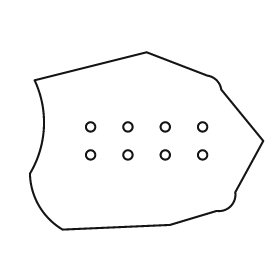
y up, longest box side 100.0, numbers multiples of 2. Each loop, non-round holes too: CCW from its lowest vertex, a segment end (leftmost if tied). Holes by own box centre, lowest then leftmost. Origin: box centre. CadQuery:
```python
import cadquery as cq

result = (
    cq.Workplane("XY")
    .moveTo(-36.0, -38.0)
    .lineTo(10.0, -36.0)
    .lineTo(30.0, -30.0)
    .threePointArc((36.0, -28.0), (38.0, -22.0))
    .lineTo(50.0, 0.0)
    .lineTo(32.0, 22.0)
    .threePointArc((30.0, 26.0), (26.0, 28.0))
    .lineTo(0.0, 38.0)
    .lineTo(-48.0, 26.0)
    .threePointArc((-44.0, 6.0), (-50.0, -14.0))
    .threePointArc((-46.0, -28.0), (-36.0, -38.0))
    .close()
    .moveTo(-24.0, -6.0)
    .circle(2.0)
    .moveTo(-8.0, -6.0)
    .circle(2.0)
    .moveTo(8.0, -6.0)
    .circle(2.0)
    .moveTo(24.0, -6.0)
    .circle(2.0)
    .moveTo(-24.0, 6.0)
    .circle(2.0)
    .moveTo(-8.0, 6.0)
    .circle(2.0)
    .moveTo(8.0, 6.0)
    .circle(2.0)
    .moveTo(24.0, 6.0)
    .circle(2.0)
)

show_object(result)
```